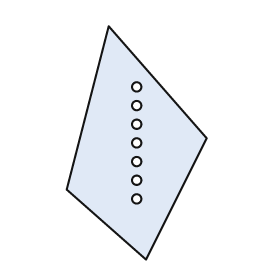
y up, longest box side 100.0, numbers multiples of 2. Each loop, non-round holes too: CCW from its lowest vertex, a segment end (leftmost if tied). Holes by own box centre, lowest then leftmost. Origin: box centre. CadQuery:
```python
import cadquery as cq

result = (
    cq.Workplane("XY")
    .moveTo(4.0, -50.0)
    .lineTo(30.0, 2.0)
    .lineTo(-12.0, 50.0)
    .lineTo(-30.0, -20.0)
    .close()
    .moveTo(0.0, -24.0)
    .circle(2.0)
    .moveTo(0.0, -16.0)
    .circle(2.0)
    .moveTo(0.0, -8.0)
    .circle(2.0)
    .moveTo(0.0, 0.0)
    .circle(2.0)
    .moveTo(0.0, 8.0)
    .circle(2.0)
    .moveTo(0.0, 16.0)
    .circle(2.0)
    .moveTo(0.0, 24.0)
    .circle(2.0)
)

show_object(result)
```